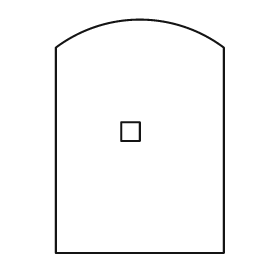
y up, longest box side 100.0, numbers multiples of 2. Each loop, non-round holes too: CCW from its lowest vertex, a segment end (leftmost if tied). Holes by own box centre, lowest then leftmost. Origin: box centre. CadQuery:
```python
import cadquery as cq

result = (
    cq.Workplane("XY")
    .moveTo(-36.0, -50.0)
    .lineTo(36.0, -50.0)
    .lineTo(36.0, 38.0)
    .threePointArc((0.0, 50.0), (-36.0, 38.0))
    .close()
    .moveTo(-8.0, -2.0)
    .lineTo(0.0, -2.0)
    .lineTo(0.0, 6.0)
    .lineTo(-8.0, 6.0)
    .close()
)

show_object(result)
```